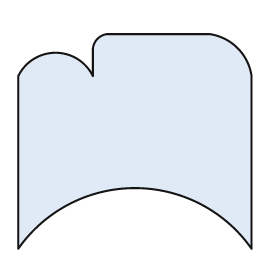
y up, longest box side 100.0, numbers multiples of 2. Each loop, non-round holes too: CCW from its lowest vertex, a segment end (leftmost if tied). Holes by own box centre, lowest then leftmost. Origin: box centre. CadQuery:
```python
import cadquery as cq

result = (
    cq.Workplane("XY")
    .moveTo(-50.0, -46.0)
    .threePointArc((0.0, -20.0), (50.0, -46.0))
    .lineTo(50.0, 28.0)
    .threePointArc((44.0, 40.0), (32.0, 46.0))
    .lineTo(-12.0, 46.0)
    .threePointArc((-16.0, 44.0), (-18.0, 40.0))
    .lineTo(-18.0, 28.0)
    .threePointArc((-34.0, 38.0), (-50.0, 28.0))
    .close()
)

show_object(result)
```